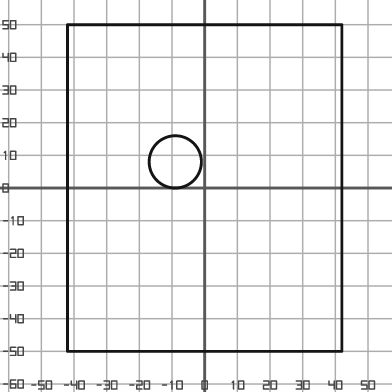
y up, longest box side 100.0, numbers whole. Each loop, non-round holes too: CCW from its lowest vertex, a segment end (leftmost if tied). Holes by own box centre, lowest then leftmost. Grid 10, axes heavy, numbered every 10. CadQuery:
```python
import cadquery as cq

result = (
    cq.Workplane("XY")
    .moveTo(-42.0, -50.0)
    .lineTo(42.0, -50.0)
    .lineTo(42.0, 50.0)
    .lineTo(-42.0, 50.0)
    .close()
    .moveTo(-9.0, 8.0)
    .circle(8.0)
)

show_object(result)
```